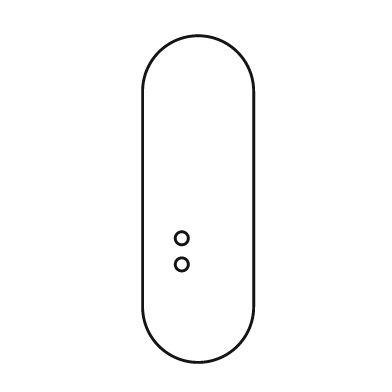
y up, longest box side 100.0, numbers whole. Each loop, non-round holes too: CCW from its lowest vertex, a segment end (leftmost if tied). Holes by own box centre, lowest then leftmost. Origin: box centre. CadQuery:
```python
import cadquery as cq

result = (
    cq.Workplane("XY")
    .moveTo(-17.0, -33.0)
    .threePointArc((0.0, -50.0), (17.0, -33.0))
    .lineTo(17.0, 33.0)
    .threePointArc((0.0, 50.0), (-17.0, 33.0))
    .close()
    .moveTo(-5.0, -20.0)
    .circle(2.0)
    .moveTo(-5.0, -12.0)
    .circle(2.0)
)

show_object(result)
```